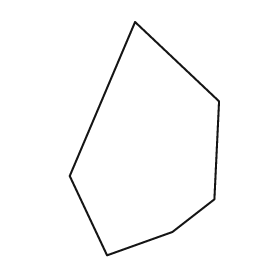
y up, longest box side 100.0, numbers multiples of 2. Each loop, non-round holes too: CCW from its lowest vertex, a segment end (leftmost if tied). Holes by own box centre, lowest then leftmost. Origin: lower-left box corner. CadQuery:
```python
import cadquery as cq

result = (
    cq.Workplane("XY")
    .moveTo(16.0, 0.0)
    .lineTo(44.0, 10.0)
    .lineTo(62.0, 24.0)
    .lineTo(64.0, 66.0)
    .lineTo(28.0, 100.0)
    .lineTo(0.0, 34.0)
    .close()
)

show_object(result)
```